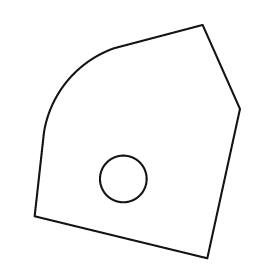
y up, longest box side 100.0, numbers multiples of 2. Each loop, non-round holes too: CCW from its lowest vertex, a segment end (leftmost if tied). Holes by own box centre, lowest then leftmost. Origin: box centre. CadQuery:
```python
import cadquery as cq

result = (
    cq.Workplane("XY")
    .moveTo(30.0, -50.0)
    .lineTo(44.0, 14.0)
    .lineTo(28.0, 50.0)
    .lineTo(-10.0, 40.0)
    .threePointArc((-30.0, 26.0), (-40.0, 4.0))
    .lineTo(-44.0, -32.0)
    .close()
    .moveTo(-6.0, -16.0)
    .circle(10.0)
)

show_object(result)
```